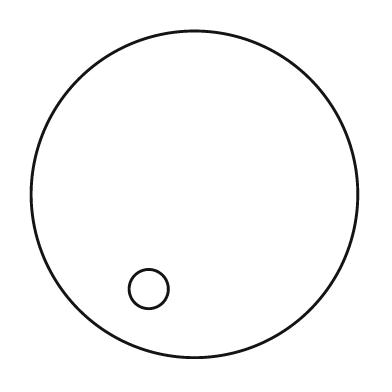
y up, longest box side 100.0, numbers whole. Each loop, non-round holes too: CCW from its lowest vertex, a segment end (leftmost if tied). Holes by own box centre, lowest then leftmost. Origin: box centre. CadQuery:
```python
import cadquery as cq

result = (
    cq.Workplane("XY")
    .moveTo(0.0, 0.0)
    .circle(50.0)
    .moveTo(-14.0, -29.0)
    .circle(6.0)
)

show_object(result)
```